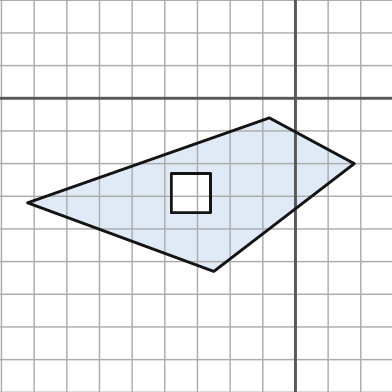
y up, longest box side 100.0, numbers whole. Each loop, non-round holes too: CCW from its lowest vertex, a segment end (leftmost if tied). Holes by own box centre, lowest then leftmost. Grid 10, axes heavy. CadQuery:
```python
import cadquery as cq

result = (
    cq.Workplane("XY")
    .moveTo(-25.0, -53.0)
    .lineTo(18.0, -20.0)
    .lineTo(-8.0, -6.0)
    .lineTo(-82.0, -32.0)
    .close()
    .moveTo(-38.0, -35.0)
    .lineTo(-26.0, -35.0)
    .lineTo(-26.0, -23.0)
    .lineTo(-38.0, -23.0)
    .close()
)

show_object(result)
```